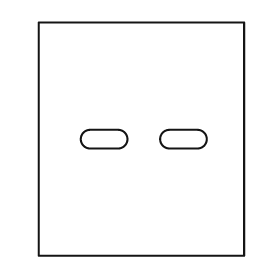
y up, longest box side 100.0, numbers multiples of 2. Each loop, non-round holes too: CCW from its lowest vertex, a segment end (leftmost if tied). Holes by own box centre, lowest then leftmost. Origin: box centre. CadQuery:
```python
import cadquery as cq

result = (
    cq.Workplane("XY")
    .moveTo(-44.0, -50.0)
    .lineTo(44.0, -50.0)
    .lineTo(44.0, 50.0)
    .lineTo(-44.0, 50.0)
    .close()
    .moveTo(-22.0, -4.0)
    .lineTo(-10.0, -4.0)
    .threePointArc((-6.0, 0.0), (-10.0, 4.0))
    .lineTo(-22.0, 4.0)
    .threePointArc((-26.0, 0.0), (-22.0, -4.0))
    .close()
    .moveTo(12.0, -4.0)
    .lineTo(24.0, -4.0)
    .threePointArc((28.0, 0.0), (24.0, 4.0))
    .lineTo(12.0, 4.0)
    .threePointArc((8.0, 0.0), (12.0, -4.0))
    .close()
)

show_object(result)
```